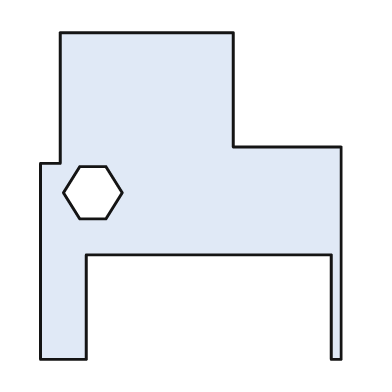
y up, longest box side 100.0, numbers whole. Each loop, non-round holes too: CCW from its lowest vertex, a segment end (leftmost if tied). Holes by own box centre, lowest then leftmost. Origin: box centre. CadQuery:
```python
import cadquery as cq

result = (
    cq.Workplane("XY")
    .moveTo(-46.0, -50.0)
    .lineTo(-32.0, -50.0)
    .lineTo(-32.0, -18.0)
    .lineTo(43.0, -18.0)
    .lineTo(43.0, -50.0)
    .lineTo(46.0, -50.0)
    .lineTo(46.0, 15.0)
    .lineTo(13.0, 15.0)
    .lineTo(13.0, 50.0)
    .lineTo(-40.0, 50.0)
    .lineTo(-40.0, 10.0)
    .lineTo(-46.0, 10.0)
    .close()
    .moveTo(-34.0, -7.0)
    .lineTo(-26.0, -7.0)
    .lineTo(-21.0, 1.0)
    .lineTo(-26.0, 9.0)
    .lineTo(-34.0, 9.0)
    .lineTo(-39.0, 1.0)
    .close()
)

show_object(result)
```